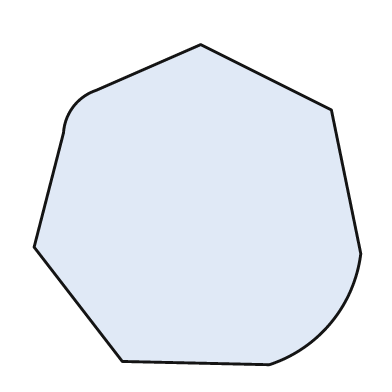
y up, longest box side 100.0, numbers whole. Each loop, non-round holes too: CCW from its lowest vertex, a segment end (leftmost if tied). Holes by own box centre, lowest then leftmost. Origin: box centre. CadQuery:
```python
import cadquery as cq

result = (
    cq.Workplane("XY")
    .moveTo(22.0, -49.0)
    .threePointArc((41.0, -36.0), (50.0, -15.0))
    .lineTo(41.0, 29.0)
    .lineTo(1.0, 49.0)
    .lineTo(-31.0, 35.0)
    .threePointArc((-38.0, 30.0), (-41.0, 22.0))
    .lineTo(-50.0, -13.0)
    .lineTo(-23.0, -48.0)
    .close()
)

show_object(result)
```